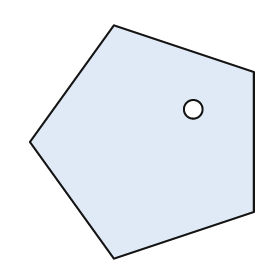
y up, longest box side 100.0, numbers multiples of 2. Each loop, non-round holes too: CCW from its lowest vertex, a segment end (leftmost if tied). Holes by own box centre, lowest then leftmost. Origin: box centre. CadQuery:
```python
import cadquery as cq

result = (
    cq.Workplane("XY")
    .moveTo(-12.0, -50.0)
    .lineTo(48.0, -30.0)
    .lineTo(48.0, 30.0)
    .lineTo(-12.0, 50.0)
    .lineTo(-48.0, 0.0)
    .close()
    .moveTo(22.0, 14.0)
    .circle(4.0)
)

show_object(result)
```